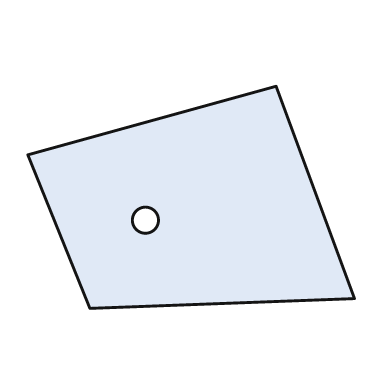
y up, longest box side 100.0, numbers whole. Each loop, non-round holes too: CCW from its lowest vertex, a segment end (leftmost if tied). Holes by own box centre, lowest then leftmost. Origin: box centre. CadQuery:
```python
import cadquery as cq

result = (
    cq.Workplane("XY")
    .moveTo(-31.0, -34.0)
    .lineTo(50.0, -31.0)
    .lineTo(26.0, 34.0)
    .lineTo(-50.0, 13.0)
    .close()
    .moveTo(-14.0, -7.0)
    .circle(4.0)
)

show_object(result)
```